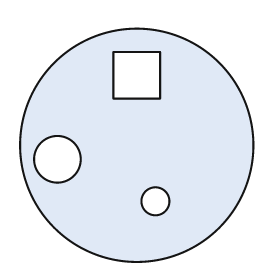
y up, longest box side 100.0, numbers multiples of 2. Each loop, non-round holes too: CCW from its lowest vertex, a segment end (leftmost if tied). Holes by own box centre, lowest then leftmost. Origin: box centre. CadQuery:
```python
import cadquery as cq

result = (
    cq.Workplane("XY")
    .moveTo(0.0, 0.0)
    .circle(50.0)
    .moveTo(8.0, -24.0)
    .circle(6.0)
    .moveTo(-34.0, -6.0)
    .circle(10.0)
    .moveTo(-10.0, 20.0)
    .lineTo(10.0, 20.0)
    .lineTo(10.0, 40.0)
    .lineTo(-10.0, 40.0)
    .close()
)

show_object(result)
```